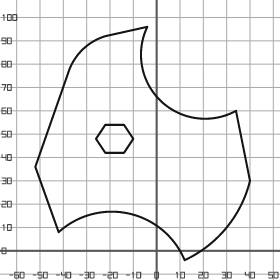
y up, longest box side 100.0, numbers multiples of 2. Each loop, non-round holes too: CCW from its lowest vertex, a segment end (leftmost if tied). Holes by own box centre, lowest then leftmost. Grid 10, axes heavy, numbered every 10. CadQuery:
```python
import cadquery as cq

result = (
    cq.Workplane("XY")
    .moveTo(12.0, -4.0)
    .threePointArc((30.0, 10.0), (40.0, 30.0))
    .lineTo(34.0, 60.0)
    .threePointArc((2.0, 64.0), (-4.0, 96.0))
    .lineTo(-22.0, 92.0)
    .threePointArc((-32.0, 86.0), (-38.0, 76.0))
    .lineTo(-52.0, 36.0)
    .lineTo(-42.0, 8.0)
    .threePointArc((-12.0, 16.0), (12.0, -4.0))
    .close()
    .moveTo(-22.0, 42.0)
    .lineTo(-14.0, 42.0)
    .lineTo(-10.0, 48.0)
    .lineTo(-14.0, 54.0)
    .lineTo(-22.0, 54.0)
    .lineTo(-26.0, 48.0)
    .close()
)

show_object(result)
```